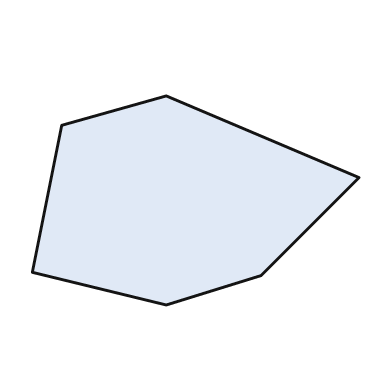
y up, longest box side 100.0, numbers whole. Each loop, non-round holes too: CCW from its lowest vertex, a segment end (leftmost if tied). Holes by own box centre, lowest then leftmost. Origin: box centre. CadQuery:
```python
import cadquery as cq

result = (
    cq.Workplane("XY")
    .moveTo(-9.0, -32.0)
    .lineTo(20.0, -23.0)
    .lineTo(50.0, 7.0)
    .lineTo(-9.0, 32.0)
    .lineTo(-41.0, 23.0)
    .lineTo(-50.0, -22.0)
    .close()
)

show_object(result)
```